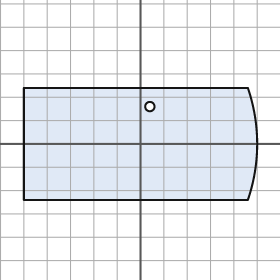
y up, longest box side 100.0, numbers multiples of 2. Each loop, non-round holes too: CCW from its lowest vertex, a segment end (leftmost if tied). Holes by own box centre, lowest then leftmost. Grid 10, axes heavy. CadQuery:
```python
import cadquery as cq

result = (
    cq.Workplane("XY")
    .moveTo(-50.0, -24.0)
    .lineTo(46.0, -24.0)
    .threePointArc((50.0, 0.0), (46.0, 24.0))
    .lineTo(-50.0, 24.0)
    .close()
    .moveTo(4.0, 16.0)
    .circle(2.0)
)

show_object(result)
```